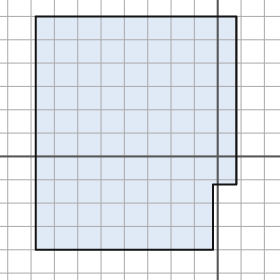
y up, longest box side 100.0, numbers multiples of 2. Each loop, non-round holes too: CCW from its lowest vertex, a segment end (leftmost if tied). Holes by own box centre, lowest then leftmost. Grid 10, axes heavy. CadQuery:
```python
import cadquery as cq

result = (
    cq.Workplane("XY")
    .moveTo(-78.0, -40.0)
    .lineTo(-2.0, -40.0)
    .lineTo(-2.0, -12.0)
    .lineTo(8.0, -12.0)
    .lineTo(8.0, 60.0)
    .lineTo(-78.0, 60.0)
    .close()
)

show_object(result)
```